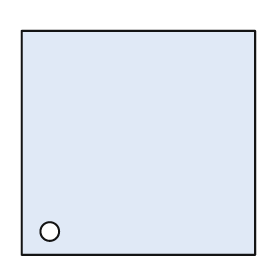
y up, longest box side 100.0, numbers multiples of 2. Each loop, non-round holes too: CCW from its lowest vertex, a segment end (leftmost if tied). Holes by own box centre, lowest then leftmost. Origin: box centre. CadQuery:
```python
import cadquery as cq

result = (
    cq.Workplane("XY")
    .moveTo(-50.0, -48.0)
    .lineTo(50.0, -48.0)
    .lineTo(50.0, 48.0)
    .lineTo(-50.0, 48.0)
    .close()
    .moveTo(-38.0, -38.0)
    .circle(4.0)
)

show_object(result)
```